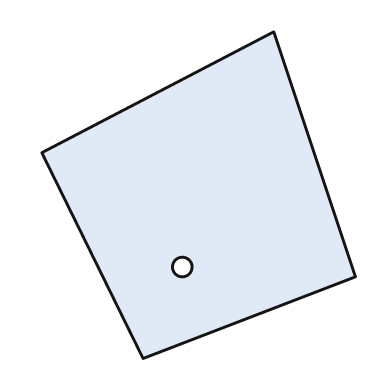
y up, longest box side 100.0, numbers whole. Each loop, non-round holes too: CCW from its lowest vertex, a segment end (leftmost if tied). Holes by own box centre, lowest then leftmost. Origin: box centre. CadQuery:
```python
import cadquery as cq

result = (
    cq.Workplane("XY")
    .moveTo(-17.0, -50.0)
    .lineTo(48.0, -25.0)
    .lineTo(23.0, 50.0)
    .lineTo(-48.0, 13.0)
    .close()
    .moveTo(-5.0, -22.0)
    .circle(3.0)
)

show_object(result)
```